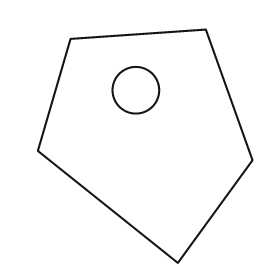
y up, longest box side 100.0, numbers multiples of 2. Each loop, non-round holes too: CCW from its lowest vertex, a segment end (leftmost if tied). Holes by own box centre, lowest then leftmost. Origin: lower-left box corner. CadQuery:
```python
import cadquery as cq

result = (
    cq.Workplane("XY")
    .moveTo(60.0, 0.0)
    .lineTo(92.0, 44.0)
    .lineTo(72.0, 100.0)
    .lineTo(14.0, 96.0)
    .lineTo(0.0, 48.0)
    .close()
    .moveTo(42.0, 74.0)
    .circle(10.0)
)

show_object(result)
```